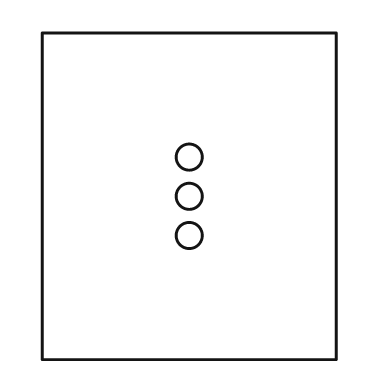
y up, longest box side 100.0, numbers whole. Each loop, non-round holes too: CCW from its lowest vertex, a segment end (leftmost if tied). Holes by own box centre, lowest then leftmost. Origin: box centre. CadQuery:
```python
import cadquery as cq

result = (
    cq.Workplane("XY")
    .moveTo(-45.0, -50.0)
    .lineTo(45.0, -50.0)
    .lineTo(45.0, 50.0)
    .lineTo(-45.0, 50.0)
    .close()
    .moveTo(0.0, -12.0)
    .circle(4.0)
    .moveTo(0.0, 0.0)
    .circle(4.0)
    .moveTo(0.0, 12.0)
    .circle(4.0)
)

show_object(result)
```